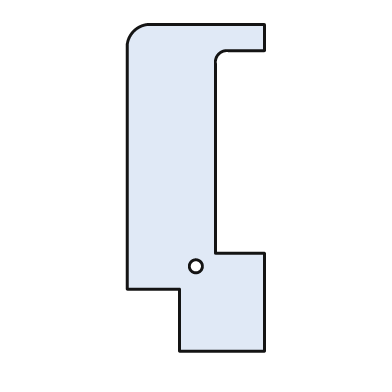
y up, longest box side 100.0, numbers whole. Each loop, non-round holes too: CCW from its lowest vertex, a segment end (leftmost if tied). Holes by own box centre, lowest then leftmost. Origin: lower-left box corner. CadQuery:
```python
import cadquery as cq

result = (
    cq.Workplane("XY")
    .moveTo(16.0, 0.0)
    .lineTo(42.0, 0.0)
    .lineTo(42.0, 30.0)
    .lineTo(27.0, 30.0)
    .lineTo(27.0, 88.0)
    .threePointArc((28.0, 91.0), (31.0, 92.0))
    .lineTo(42.0, 92.0)
    .lineTo(42.0, 100.0)
    .lineTo(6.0, 100.0)
    .threePointArc((2.0, 98.0), (0.0, 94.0))
    .lineTo(0.0, 19.0)
    .lineTo(16.0, 19.0)
    .close()
    .moveTo(21.0, 26.0)
    .circle(2.0)
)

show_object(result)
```